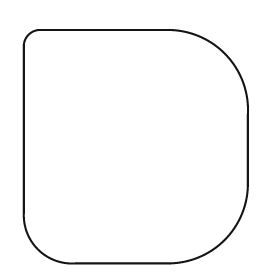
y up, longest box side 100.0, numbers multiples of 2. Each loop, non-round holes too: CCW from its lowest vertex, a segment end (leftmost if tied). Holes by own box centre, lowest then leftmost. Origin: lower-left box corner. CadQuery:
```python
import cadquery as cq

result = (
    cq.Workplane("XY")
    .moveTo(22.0, 0.0)
    .lineTo(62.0, 0.0)
    .threePointArc((86.0, 10.0), (96.0, 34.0))
    .lineTo(96.0, 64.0)
    .threePointArc((86.0, 90.0), (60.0, 100.0))
    .lineTo(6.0, 100.0)
    .threePointArc((2.0, 98.0), (0.0, 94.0))
    .lineTo(0.0, 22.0)
    .threePointArc((6.0, 6.0), (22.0, 0.0))
    .close()
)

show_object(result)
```